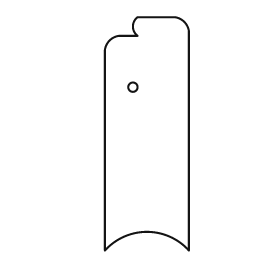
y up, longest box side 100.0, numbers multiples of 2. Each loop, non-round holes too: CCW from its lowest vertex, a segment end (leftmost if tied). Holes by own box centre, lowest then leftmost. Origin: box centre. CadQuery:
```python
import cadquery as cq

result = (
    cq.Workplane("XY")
    .moveTo(-18.0, -50.0)
    .threePointArc((0.0, -42.0), (18.0, -50.0))
    .lineTo(18.0, 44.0)
    .threePointArc((16.0, 48.0), (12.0, 50.0))
    .lineTo(-4.0, 50.0)
    .threePointArc((-6.0, 46.0), (-4.0, 42.0))
    .lineTo(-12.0, 42.0)
    .threePointArc((-16.0, 40.0), (-18.0, 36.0))
    .close()
    .moveTo(-6.0, 20.0)
    .circle(2.0)
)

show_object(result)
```